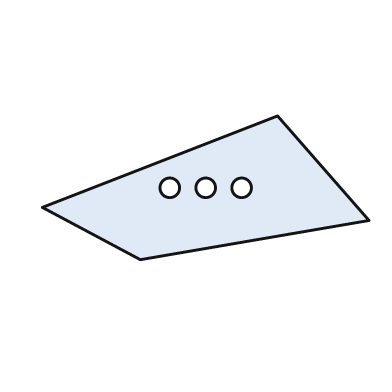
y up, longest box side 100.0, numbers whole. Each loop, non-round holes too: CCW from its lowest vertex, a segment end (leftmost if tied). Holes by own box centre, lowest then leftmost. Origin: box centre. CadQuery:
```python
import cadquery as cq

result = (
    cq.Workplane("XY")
    .moveTo(-20.0, -22.0)
    .lineTo(50.0, -10.0)
    .lineTo(22.0, 22.0)
    .lineTo(-50.0, -6.0)
    .close()
    .moveTo(-11.0, 0.0)
    .circle(3.0)
    .moveTo(0.0, 0.0)
    .circle(3.0)
    .moveTo(11.0, 0.0)
    .circle(3.0)
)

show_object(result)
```